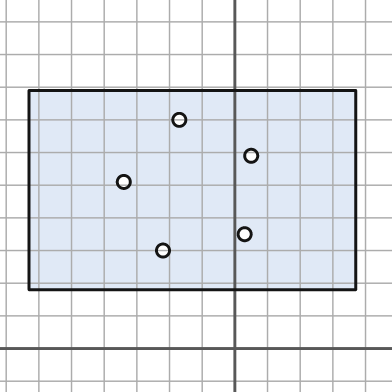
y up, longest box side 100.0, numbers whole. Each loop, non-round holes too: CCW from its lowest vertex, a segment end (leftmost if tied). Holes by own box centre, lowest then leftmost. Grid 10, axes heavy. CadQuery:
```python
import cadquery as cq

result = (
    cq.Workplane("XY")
    .moveTo(-63.0, 18.0)
    .lineTo(37.0, 18.0)
    .lineTo(37.0, 79.0)
    .lineTo(-63.0, 79.0)
    .close()
    .moveTo(-22.0, 30.0)
    .circle(2.0)
    .moveTo(3.0, 35.0)
    .circle(2.0)
    .moveTo(-34.0, 51.0)
    .circle(2.0)
    .moveTo(5.0, 59.0)
    .circle(2.0)
    .moveTo(-17.0, 70.0)
    .circle(2.0)
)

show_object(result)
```